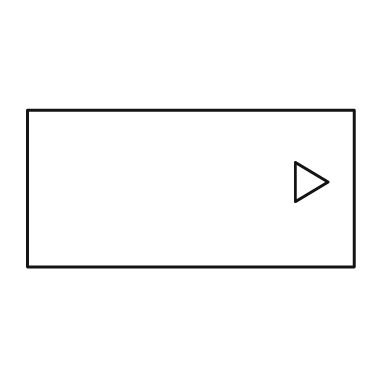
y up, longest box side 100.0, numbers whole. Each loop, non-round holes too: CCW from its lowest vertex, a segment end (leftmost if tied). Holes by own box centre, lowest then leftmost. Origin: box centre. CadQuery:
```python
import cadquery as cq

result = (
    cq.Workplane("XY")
    .moveTo(-50.0, -24.0)
    .lineTo(50.0, -24.0)
    .lineTo(50.0, 24.0)
    .lineTo(-50.0, 24.0)
    .close()
    .moveTo(32.0, -4.0)
    .lineTo(42.0, 2.0)
    .lineTo(32.0, 8.0)
    .close()
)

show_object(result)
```